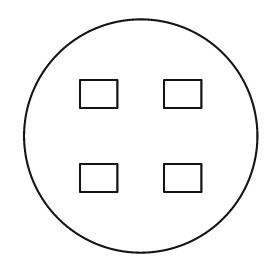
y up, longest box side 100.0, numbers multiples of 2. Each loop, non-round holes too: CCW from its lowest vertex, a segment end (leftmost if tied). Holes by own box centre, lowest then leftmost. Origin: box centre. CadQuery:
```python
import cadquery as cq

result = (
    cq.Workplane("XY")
    .moveTo(0.0, 0.0)
    .circle(50.0)
    .moveTo(-26.0, -24.0)
    .lineTo(-10.0, -24.0)
    .lineTo(-10.0, -12.0)
    .lineTo(-26.0, -12.0)
    .close()
    .moveTo(10.0, -24.0)
    .lineTo(26.0, -24.0)
    .lineTo(26.0, -12.0)
    .lineTo(10.0, -12.0)
    .close()
    .moveTo(-26.0, 12.0)
    .lineTo(-10.0, 12.0)
    .lineTo(-10.0, 24.0)
    .lineTo(-26.0, 24.0)
    .close()
    .moveTo(10.0, 12.0)
    .lineTo(26.0, 12.0)
    .lineTo(26.0, 24.0)
    .lineTo(10.0, 24.0)
    .close()
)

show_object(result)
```